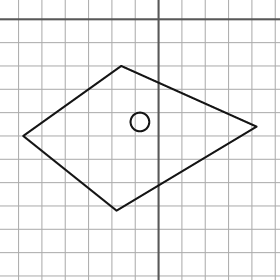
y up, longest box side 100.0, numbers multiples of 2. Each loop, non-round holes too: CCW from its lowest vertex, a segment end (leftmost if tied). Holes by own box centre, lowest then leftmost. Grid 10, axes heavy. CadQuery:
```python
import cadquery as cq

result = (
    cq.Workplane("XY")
    .moveTo(-18.0, -82.0)
    .lineTo(42.0, -46.0)
    .lineTo(-16.0, -20.0)
    .lineTo(-58.0, -50.0)
    .close()
    .moveTo(-8.0, -44.0)
    .circle(4.0)
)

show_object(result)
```